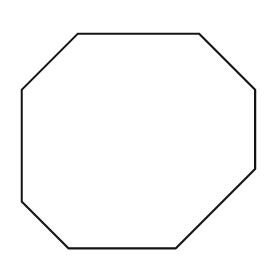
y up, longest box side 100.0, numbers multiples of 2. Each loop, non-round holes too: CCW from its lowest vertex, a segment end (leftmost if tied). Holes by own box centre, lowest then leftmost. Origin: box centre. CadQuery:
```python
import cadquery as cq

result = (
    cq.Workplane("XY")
    .moveTo(-30.0, -46.0)
    .lineTo(16.0, -46.0)
    .lineTo(50.0, -12.0)
    .lineTo(50.0, 22.0)
    .lineTo(26.0, 46.0)
    .lineTo(-26.0, 46.0)
    .lineTo(-50.0, 22.0)
    .lineTo(-50.0, -26.0)
    .close()
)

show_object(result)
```